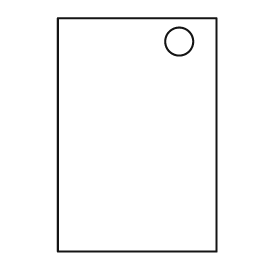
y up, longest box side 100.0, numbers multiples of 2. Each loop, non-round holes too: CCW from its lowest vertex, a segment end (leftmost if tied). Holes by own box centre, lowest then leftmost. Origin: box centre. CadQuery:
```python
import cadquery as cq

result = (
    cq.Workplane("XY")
    .moveTo(-34.0, -50.0)
    .lineTo(34.0, -50.0)
    .lineTo(34.0, 50.0)
    .lineTo(-34.0, 50.0)
    .close()
    .moveTo(18.0, 40.0)
    .circle(6.0)
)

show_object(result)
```